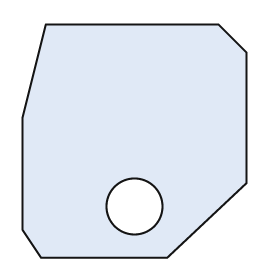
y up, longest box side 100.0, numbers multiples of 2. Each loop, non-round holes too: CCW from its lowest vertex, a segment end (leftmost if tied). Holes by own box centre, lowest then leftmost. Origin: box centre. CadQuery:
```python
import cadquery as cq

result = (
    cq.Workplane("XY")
    .moveTo(-40.0, -50.0)
    .lineTo(14.0, -50.0)
    .lineTo(48.0, -18.0)
    .lineTo(48.0, 38.0)
    .lineTo(36.0, 50.0)
    .lineTo(-38.0, 50.0)
    .lineTo(-48.0, 10.0)
    .lineTo(-48.0, -38.0)
    .close()
    .moveTo(0.0, -28.0)
    .circle(12.0)
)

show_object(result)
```